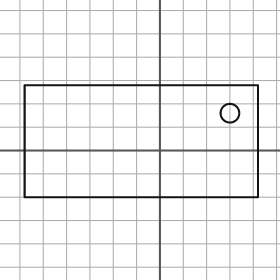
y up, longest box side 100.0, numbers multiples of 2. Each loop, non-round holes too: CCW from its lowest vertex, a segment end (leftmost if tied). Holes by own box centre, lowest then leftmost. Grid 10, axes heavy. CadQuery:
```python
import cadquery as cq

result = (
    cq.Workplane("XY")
    .moveTo(-58.0, -20.0)
    .lineTo(42.0, -20.0)
    .lineTo(42.0, 28.0)
    .lineTo(-58.0, 28.0)
    .close()
    .moveTo(30.0, 16.0)
    .circle(4.0)
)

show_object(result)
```